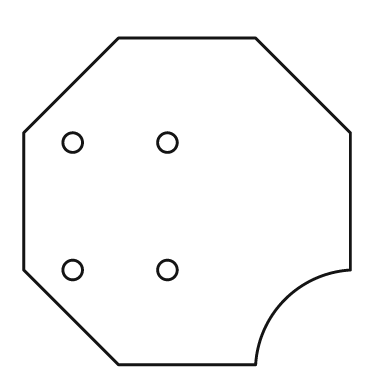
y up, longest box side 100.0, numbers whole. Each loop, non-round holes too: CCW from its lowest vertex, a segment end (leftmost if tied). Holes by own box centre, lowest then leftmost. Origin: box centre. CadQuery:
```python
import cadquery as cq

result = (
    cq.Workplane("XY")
    .moveTo(-21.0, -50.0)
    .lineTo(21.0, -50.0)
    .threePointArc((30.0, -30.0), (50.0, -21.0))
    .lineTo(50.0, 21.0)
    .lineTo(21.0, 50.0)
    .lineTo(-21.0, 50.0)
    .lineTo(-50.0, 21.0)
    .lineTo(-50.0, -21.0)
    .close()
    .moveTo(-35.0, -21.0)
    .circle(3.0)
    .moveTo(-6.0, -21.0)
    .circle(3.0)
    .moveTo(-35.0, 18.0)
    .circle(3.0)
    .moveTo(-6.0, 18.0)
    .circle(3.0)
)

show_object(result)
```